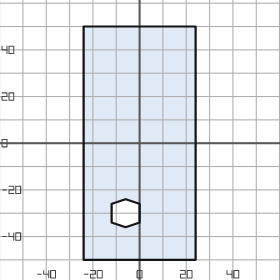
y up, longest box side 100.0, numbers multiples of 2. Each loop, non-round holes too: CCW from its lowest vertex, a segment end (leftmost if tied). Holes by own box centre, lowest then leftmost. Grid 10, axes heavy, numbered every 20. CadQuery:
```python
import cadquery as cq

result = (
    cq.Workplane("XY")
    .moveTo(-24.0, -50.0)
    .lineTo(24.0, -50.0)
    .lineTo(24.0, 50.0)
    .lineTo(-24.0, 50.0)
    .close()
    .moveTo(-6.0, -36.0)
    .lineTo(0.0, -34.0)
    .lineTo(0.0, -26.0)
    .lineTo(-6.0, -24.0)
    .lineTo(-12.0, -26.0)
    .lineTo(-12.0, -34.0)
    .close()
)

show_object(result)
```